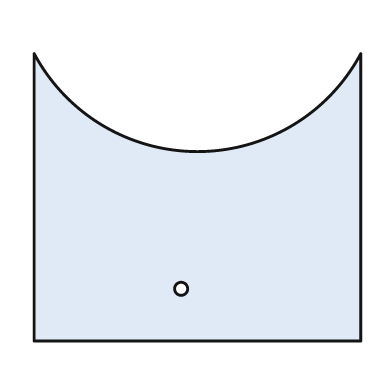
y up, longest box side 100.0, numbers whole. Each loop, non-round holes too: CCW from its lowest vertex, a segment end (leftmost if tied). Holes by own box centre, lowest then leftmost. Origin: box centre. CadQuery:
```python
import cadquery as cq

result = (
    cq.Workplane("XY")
    .moveTo(-50.0, -44.0)
    .lineTo(50.0, -44.0)
    .lineTo(50.0, 44.0)
    .threePointArc((0.0, 14.0), (-50.0, 44.0))
    .close()
    .moveTo(-5.0, -28.0)
    .circle(2.0)
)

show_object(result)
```